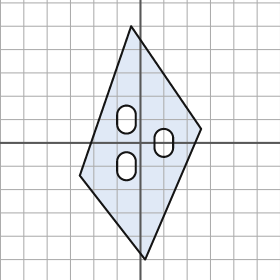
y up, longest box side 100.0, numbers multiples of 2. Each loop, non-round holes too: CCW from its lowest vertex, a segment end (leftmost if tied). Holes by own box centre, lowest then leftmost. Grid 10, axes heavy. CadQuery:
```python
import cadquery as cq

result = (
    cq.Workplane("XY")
    .moveTo(2.0, -50.0)
    .lineTo(26.0, 6.0)
    .lineTo(-4.0, 50.0)
    .lineTo(-26.0, -14.0)
    .close()
    .moveTo(-10.0, -12.0)
    .threePointArc((-6.0, -16.0), (-2.0, -12.0))
    .lineTo(-2.0, -8.0)
    .threePointArc((-6.0, -4.0), (-10.0, -8.0))
    .close()
    .moveTo(6.0, -2.0)
    .threePointArc((10.0, -6.0), (14.0, -2.0))
    .lineTo(14.0, 2.0)
    .threePointArc((10.0, 6.0), (6.0, 2.0))
    .close()
    .moveTo(-10.0, 8.0)
    .threePointArc((-6.0, 4.0), (-2.0, 8.0))
    .lineTo(-2.0, 12.0)
    .threePointArc((-6.0, 16.0), (-10.0, 12.0))
    .close()
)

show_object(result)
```